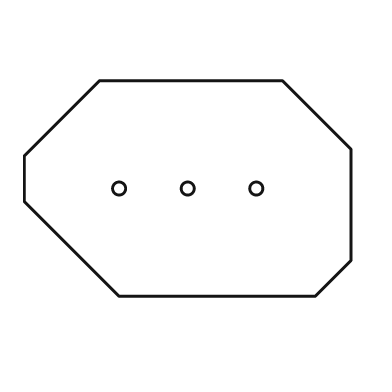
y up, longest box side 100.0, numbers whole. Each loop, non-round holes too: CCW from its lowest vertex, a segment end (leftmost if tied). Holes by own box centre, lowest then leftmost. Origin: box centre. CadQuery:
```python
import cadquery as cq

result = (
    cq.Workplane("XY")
    .moveTo(-21.0, -33.0)
    .lineTo(39.0, -33.0)
    .lineTo(50.0, -22.0)
    .lineTo(50.0, 12.0)
    .lineTo(29.0, 33.0)
    .lineTo(-27.0, 33.0)
    .lineTo(-50.0, 10.0)
    .lineTo(-50.0, -4.0)
    .close()
    .moveTo(-21.0, 0.0)
    .circle(2.0)
    .moveTo(0.0, 0.0)
    .circle(2.0)
    .moveTo(21.0, 0.0)
    .circle(2.0)
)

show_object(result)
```